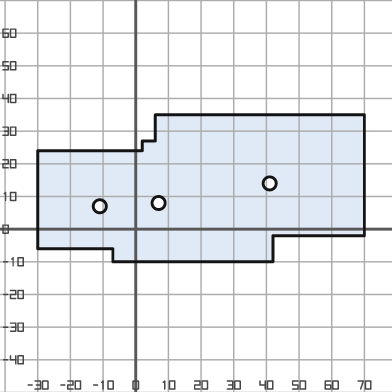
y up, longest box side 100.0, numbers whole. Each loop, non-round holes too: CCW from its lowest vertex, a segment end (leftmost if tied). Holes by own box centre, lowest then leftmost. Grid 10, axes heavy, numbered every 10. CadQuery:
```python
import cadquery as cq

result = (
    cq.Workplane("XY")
    .moveTo(-7.0, -10.0)
    .lineTo(42.0, -10.0)
    .lineTo(42.0, -2.0)
    .lineTo(70.0, -2.0)
    .lineTo(70.0, 35.0)
    .lineTo(6.0, 35.0)
    .lineTo(6.0, 27.0)
    .lineTo(2.0, 27.0)
    .lineTo(2.0, 24.0)
    .lineTo(-30.0, 24.0)
    .lineTo(-30.0, -6.0)
    .lineTo(-7.0, -6.0)
    .close()
    .moveTo(-11.0, 7.0)
    .circle(2.0)
    .moveTo(7.0, 8.0)
    .circle(2.0)
    .moveTo(41.0, 14.0)
    .circle(2.0)
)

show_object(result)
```